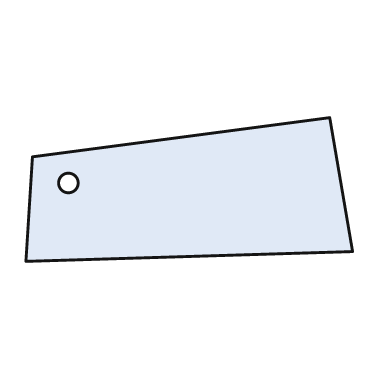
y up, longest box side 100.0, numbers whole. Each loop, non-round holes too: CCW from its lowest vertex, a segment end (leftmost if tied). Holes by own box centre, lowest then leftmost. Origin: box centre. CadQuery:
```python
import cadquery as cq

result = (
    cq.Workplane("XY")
    .moveTo(-50.0, -22.0)
    .lineTo(50.0, -19.0)
    .lineTo(43.0, 22.0)
    .lineTo(-48.0, 10.0)
    .close()
    .moveTo(-37.0, 2.0)
    .circle(3.0)
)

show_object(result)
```